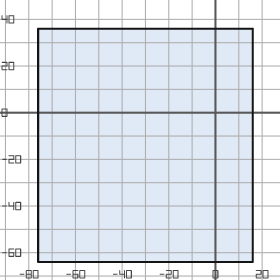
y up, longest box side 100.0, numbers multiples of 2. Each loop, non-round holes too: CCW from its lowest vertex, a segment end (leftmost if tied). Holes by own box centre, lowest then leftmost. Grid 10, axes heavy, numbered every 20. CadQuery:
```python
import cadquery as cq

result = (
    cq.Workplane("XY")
    .moveTo(-76.0, -64.0)
    .lineTo(16.0, -64.0)
    .lineTo(16.0, 36.0)
    .lineTo(-76.0, 36.0)
    .close()
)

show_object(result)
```